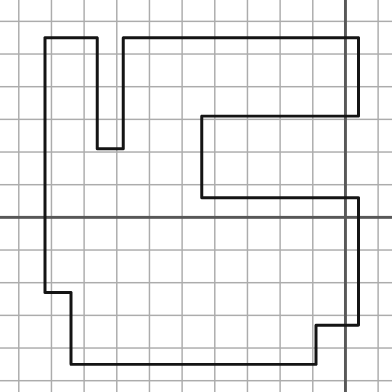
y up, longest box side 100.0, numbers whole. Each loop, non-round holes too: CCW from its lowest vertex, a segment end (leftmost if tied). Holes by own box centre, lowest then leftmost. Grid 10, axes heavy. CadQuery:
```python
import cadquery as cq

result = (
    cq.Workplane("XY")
    .moveTo(-84.0, -45.0)
    .lineTo(-9.0, -45.0)
    .lineTo(-9.0, -33.0)
    .lineTo(4.0, -33.0)
    .lineTo(4.0, 6.0)
    .lineTo(-44.0, 6.0)
    .lineTo(-44.0, 31.0)
    .lineTo(4.0, 31.0)
    .lineTo(4.0, 55.0)
    .lineTo(-68.0, 55.0)
    .lineTo(-68.0, 21.0)
    .lineTo(-76.0, 21.0)
    .lineTo(-76.0, 55.0)
    .lineTo(-92.0, 55.0)
    .lineTo(-92.0, -23.0)
    .lineTo(-84.0, -23.0)
    .close()
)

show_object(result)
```